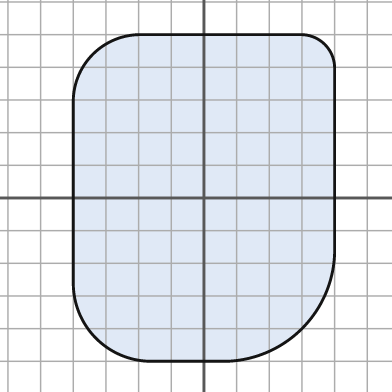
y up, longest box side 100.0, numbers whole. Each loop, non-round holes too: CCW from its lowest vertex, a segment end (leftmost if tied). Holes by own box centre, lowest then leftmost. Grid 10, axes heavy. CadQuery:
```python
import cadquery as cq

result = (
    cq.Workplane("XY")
    .moveTo(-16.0, -50.0)
    .lineTo(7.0, -50.0)
    .threePointArc((30.0, -40.0), (40.0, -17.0))
    .lineTo(40.0, 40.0)
    .threePointArc((37.0, 47.0), (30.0, 50.0))
    .lineTo(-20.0, 50.0)
    .threePointArc((-34.0, 44.0), (-40.0, 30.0))
    .lineTo(-40.0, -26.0)
    .threePointArc((-33.0, -43.0), (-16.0, -50.0))
    .close()
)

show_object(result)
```